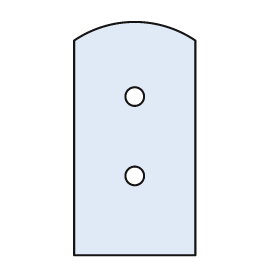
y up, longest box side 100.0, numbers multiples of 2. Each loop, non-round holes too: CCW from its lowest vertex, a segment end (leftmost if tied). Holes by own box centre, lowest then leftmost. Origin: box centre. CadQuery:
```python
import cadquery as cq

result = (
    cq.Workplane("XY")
    .moveTo(-26.0, -50.0)
    .lineTo(26.0, -50.0)
    .lineTo(26.0, 42.0)
    .threePointArc((0.0, 50.0), (-26.0, 42.0))
    .close()
    .moveTo(0.0, -16.0)
    .circle(4.0)
    .moveTo(0.0, 18.0)
    .circle(4.0)
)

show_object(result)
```